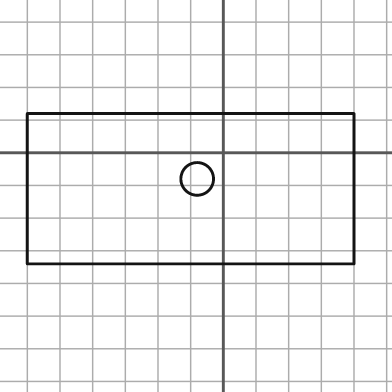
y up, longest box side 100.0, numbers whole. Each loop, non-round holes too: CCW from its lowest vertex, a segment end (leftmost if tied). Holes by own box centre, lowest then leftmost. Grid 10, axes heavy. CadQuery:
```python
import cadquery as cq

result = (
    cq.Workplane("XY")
    .moveTo(-60.0, -34.0)
    .lineTo(40.0, -34.0)
    .lineTo(40.0, 12.0)
    .lineTo(-60.0, 12.0)
    .close()
    .moveTo(-8.0, -8.0)
    .circle(5.0)
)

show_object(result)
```